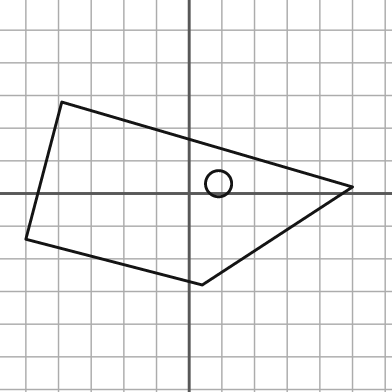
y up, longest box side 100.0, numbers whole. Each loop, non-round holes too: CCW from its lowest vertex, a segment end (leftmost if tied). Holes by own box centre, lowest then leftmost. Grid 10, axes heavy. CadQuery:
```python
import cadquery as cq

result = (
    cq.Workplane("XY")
    .moveTo(4.0, -28.0)
    .lineTo(50.0, 2.0)
    .lineTo(-39.0, 28.0)
    .lineTo(-50.0, -14.0)
    .close()
    .moveTo(9.0, 3.0)
    .circle(4.0)
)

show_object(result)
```